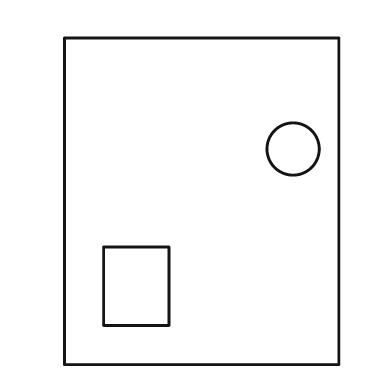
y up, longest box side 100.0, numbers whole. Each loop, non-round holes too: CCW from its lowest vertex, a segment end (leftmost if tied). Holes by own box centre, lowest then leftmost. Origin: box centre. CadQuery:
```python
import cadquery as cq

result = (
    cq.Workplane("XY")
    .moveTo(-42.0, -50.0)
    .lineTo(42.0, -50.0)
    .lineTo(42.0, 50.0)
    .lineTo(-42.0, 50.0)
    .close()
    .moveTo(-30.0, -38.0)
    .lineTo(-10.0, -38.0)
    .lineTo(-10.0, -14.0)
    .lineTo(-30.0, -14.0)
    .close()
    .moveTo(28.0, 16.0)
    .circle(8.0)
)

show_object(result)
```